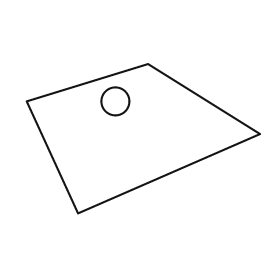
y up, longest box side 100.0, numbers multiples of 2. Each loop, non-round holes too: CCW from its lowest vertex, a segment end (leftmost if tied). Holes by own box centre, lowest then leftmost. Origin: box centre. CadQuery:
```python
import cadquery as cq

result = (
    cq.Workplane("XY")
    .moveTo(-28.0, -32.0)
    .lineTo(50.0, 2.0)
    .lineTo(2.0, 32.0)
    .lineTo(-50.0, 16.0)
    .close()
    .moveTo(-12.0, 16.0)
    .circle(6.0)
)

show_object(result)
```